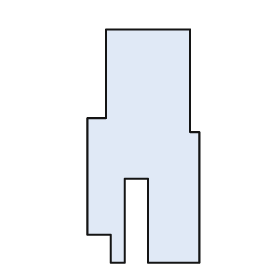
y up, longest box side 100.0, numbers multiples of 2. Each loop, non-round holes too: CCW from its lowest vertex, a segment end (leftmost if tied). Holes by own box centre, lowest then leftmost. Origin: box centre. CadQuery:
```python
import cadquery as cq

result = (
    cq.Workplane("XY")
    .moveTo(-14.0, -50.0)
    .lineTo(-8.0, -50.0)
    .lineTo(-8.0, -14.0)
    .lineTo(2.0, -14.0)
    .lineTo(2.0, -50.0)
    .lineTo(24.0, -50.0)
    .lineTo(24.0, 6.0)
    .lineTo(20.0, 6.0)
    .lineTo(20.0, 50.0)
    .lineTo(-16.0, 50.0)
    .lineTo(-16.0, 12.0)
    .lineTo(-24.0, 12.0)
    .lineTo(-24.0, -38.0)
    .lineTo(-14.0, -38.0)
    .close()
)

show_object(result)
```